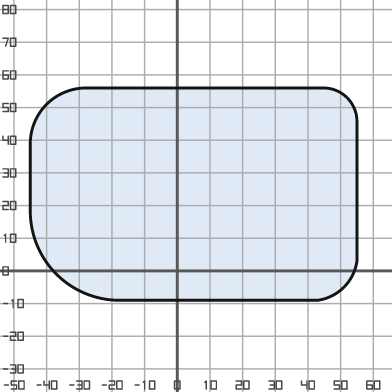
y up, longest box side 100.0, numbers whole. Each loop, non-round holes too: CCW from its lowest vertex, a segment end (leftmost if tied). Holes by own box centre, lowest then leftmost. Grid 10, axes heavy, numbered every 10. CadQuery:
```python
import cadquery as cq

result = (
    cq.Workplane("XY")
    .moveTo(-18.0, -9.0)
    .lineTo(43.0, -9.0)
    .threePointArc((51.0, -5.0), (55.0, 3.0))
    .lineTo(55.0, 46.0)
    .threePointArc((52.0, 53.0), (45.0, 56.0))
    .lineTo(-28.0, 56.0)
    .threePointArc((-40.0, 51.0), (-45.0, 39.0))
    .lineTo(-45.0, 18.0)
    .threePointArc((-37.0, -1.0), (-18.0, -9.0))
    .close()
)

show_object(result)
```